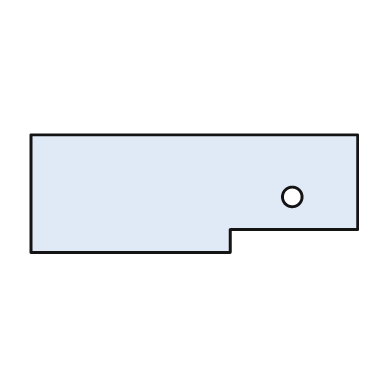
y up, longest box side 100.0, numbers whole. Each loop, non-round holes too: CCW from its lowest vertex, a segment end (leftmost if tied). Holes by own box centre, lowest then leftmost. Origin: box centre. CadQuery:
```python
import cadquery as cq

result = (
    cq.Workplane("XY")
    .moveTo(-50.0, -18.0)
    .lineTo(11.0, -18.0)
    .lineTo(11.0, -11.0)
    .lineTo(50.0, -11.0)
    .lineTo(50.0, 18.0)
    .lineTo(-50.0, 18.0)
    .close()
    .moveTo(30.0, -1.0)
    .circle(3.0)
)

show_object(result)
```